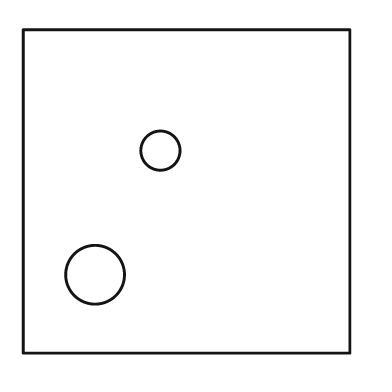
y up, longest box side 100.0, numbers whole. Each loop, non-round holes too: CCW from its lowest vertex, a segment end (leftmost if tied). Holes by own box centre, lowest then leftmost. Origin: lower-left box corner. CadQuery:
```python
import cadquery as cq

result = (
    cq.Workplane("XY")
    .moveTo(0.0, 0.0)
    .lineTo(100.0, 0.0)
    .lineTo(100.0, 99.0)
    .lineTo(0.0, 99.0)
    .close()
    .moveTo(22.0, 24.0)
    .circle(9.0)
    .moveTo(42.0, 62.0)
    .circle(6.0)
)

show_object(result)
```